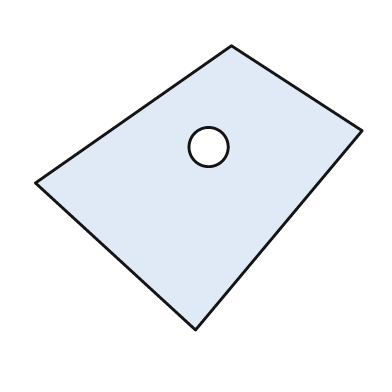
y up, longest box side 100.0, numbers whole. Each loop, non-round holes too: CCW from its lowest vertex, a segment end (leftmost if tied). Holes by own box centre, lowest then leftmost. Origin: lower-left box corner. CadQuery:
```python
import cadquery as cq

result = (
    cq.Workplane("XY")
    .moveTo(49.0, 0.0)
    .lineTo(100.0, 61.0)
    .lineTo(60.0, 87.0)
    .lineTo(0.0, 45.0)
    .close()
    .moveTo(53.0, 56.0)
    .circle(6.0)
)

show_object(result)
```